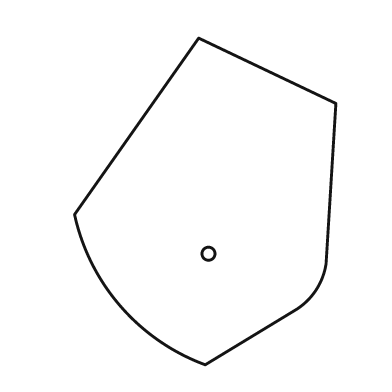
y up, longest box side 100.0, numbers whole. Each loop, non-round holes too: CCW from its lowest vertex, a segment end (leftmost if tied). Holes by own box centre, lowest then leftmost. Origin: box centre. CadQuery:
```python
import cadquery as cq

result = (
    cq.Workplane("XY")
    .moveTo(0.0, -50.0)
    .lineTo(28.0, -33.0)
    .threePointArc((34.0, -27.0), (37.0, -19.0))
    .lineTo(40.0, 30.0)
    .lineTo(-2.0, 50.0)
    .lineTo(-40.0, -4.0)
    .threePointArc((-26.0, -32.0), (0.0, -50.0))
    .close()
    .moveTo(1.0, -16.0)
    .circle(2.0)
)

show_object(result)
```